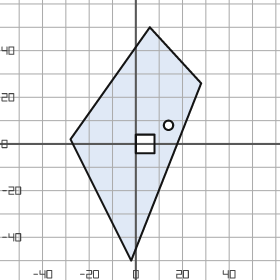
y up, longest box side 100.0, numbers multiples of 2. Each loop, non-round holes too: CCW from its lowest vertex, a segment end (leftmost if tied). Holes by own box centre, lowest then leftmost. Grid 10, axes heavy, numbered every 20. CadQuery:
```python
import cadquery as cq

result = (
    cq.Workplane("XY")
    .moveTo(-2.0, -50.0)
    .lineTo(28.0, 26.0)
    .lineTo(6.0, 50.0)
    .lineTo(-28.0, 2.0)
    .close()
    .moveTo(0.0, -4.0)
    .lineTo(8.0, -4.0)
    .lineTo(8.0, 4.0)
    .lineTo(0.0, 4.0)
    .close()
    .moveTo(14.0, 8.0)
    .circle(2.0)
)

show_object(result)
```